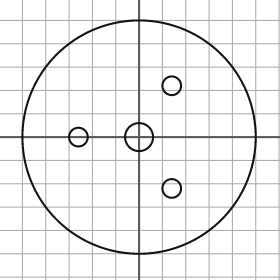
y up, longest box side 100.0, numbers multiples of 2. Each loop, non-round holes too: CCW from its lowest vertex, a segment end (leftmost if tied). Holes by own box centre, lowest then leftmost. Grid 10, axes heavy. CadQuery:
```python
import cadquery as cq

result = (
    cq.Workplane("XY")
    .moveTo(0.0, 0.0)
    .circle(50.0)
    .moveTo(14.0, -22.0)
    .circle(4.0)
    .moveTo(-26.0, 0.0)
    .circle(4.0)
    .moveTo(0.0, 0.0)
    .circle(6.0)
    .moveTo(14.0, 22.0)
    .circle(4.0)
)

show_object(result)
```